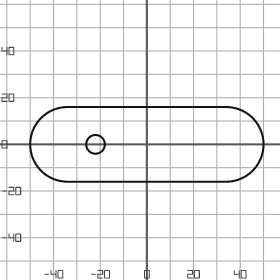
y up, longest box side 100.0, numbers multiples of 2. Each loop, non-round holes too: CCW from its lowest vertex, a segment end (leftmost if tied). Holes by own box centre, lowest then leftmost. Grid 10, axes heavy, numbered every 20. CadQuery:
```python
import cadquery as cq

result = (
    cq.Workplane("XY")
    .moveTo(-34.0, -16.0)
    .lineTo(34.0, -16.0)
    .threePointArc((50.0, 0.0), (34.0, 16.0))
    .lineTo(-34.0, 16.0)
    .threePointArc((-50.0, 0.0), (-34.0, -16.0))
    .close()
    .moveTo(-22.0, 0.0)
    .circle(4.0)
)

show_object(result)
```